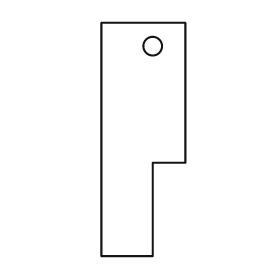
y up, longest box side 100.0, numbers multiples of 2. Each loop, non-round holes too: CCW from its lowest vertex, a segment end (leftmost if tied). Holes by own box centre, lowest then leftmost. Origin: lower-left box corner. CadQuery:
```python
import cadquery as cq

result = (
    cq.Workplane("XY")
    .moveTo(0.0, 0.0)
    .lineTo(22.0, 0.0)
    .lineTo(22.0, 40.0)
    .lineTo(36.0, 40.0)
    .lineTo(36.0, 100.0)
    .lineTo(0.0, 100.0)
    .close()
    .moveTo(22.0, 90.0)
    .circle(4.0)
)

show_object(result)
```